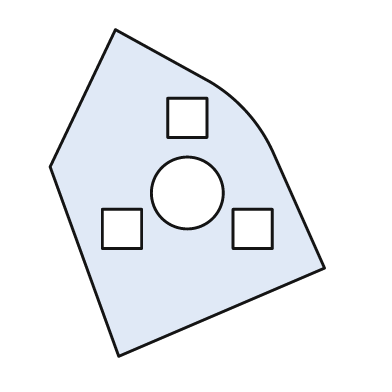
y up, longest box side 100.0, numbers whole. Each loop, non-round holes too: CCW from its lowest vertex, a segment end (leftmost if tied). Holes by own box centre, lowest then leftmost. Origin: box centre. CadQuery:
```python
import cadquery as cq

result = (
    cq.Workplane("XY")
    .moveTo(-21.0, -50.0)
    .lineTo(42.0, -23.0)
    .lineTo(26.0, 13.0)
    .threePointArc((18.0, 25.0), (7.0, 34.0))
    .lineTo(-22.0, 50.0)
    .lineTo(-42.0, 8.0)
    .close()
    .moveTo(-26.0, -17.0)
    .lineTo(-14.0, -17.0)
    .lineTo(-14.0, -5.0)
    .lineTo(-26.0, -5.0)
    .close()
    .moveTo(14.0, -17.0)
    .lineTo(26.0, -17.0)
    .lineTo(26.0, -5.0)
    .lineTo(14.0, -5.0)
    .close()
    .moveTo(0.0, 0.0)
    .circle(11.0)
    .moveTo(-6.0, 17.0)
    .lineTo(6.0, 17.0)
    .lineTo(6.0, 29.0)
    .lineTo(-6.0, 29.0)
    .close()
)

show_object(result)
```